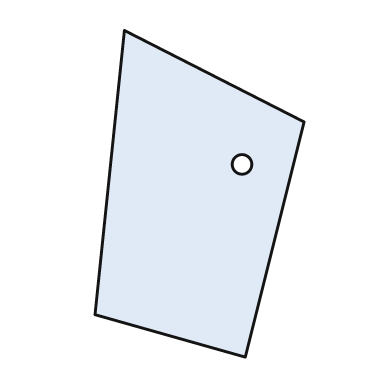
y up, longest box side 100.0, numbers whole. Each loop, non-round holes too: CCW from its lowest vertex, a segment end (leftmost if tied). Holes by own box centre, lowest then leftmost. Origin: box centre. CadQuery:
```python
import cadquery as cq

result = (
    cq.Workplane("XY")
    .moveTo(14.0, -50.0)
    .lineTo(32.0, 22.0)
    .lineTo(-23.0, 50.0)
    .lineTo(-32.0, -37.0)
    .close()
    .moveTo(13.0, 9.0)
    .circle(3.0)
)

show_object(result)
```